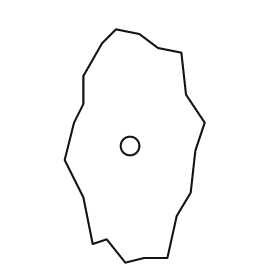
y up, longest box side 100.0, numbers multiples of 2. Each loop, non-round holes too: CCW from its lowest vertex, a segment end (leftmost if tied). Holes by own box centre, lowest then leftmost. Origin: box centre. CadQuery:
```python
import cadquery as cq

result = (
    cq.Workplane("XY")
    .moveTo(-4.0, -50.0)
    .lineTo(4.0, -48.0)
    .lineTo(14.0, -48.0)
    .lineTo(18.0, -30.0)
    .lineTo(24.0, -20.0)
    .lineTo(26.0, -2.0)
    .lineTo(30.0, 10.0)
    .lineTo(22.0, 22.0)
    .lineTo(20.0, 40.0)
    .lineTo(10.0, 42.0)
    .lineTo(2.0, 48.0)
    .lineTo(-8.0, 50.0)
    .lineTo(-14.0, 44.0)
    .lineTo(-22.0, 30.0)
    .lineTo(-22.0, 18.0)
    .lineTo(-26.0, 10.0)
    .lineTo(-30.0, -6.0)
    .lineTo(-22.0, -22.0)
    .lineTo(-18.0, -42.0)
    .lineTo(-12.0, -40.0)
    .close()
    .moveTo(-2.0, 0.0)
    .circle(4.0)
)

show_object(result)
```